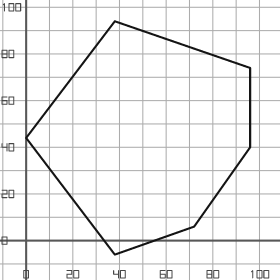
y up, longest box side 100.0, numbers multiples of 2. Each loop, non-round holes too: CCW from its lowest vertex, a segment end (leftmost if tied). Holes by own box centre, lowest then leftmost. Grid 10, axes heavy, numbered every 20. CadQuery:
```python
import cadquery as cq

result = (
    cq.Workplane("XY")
    .moveTo(38.0, -6.0)
    .lineTo(72.0, 6.0)
    .lineTo(96.0, 40.0)
    .lineTo(96.0, 74.0)
    .lineTo(38.0, 94.0)
    .lineTo(0.0, 44.0)
    .close()
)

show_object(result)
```